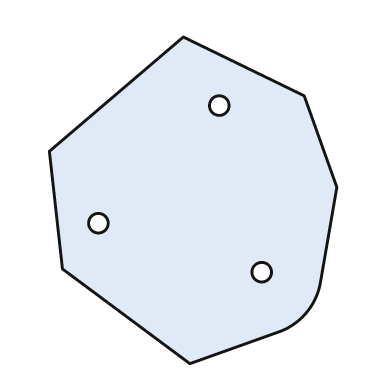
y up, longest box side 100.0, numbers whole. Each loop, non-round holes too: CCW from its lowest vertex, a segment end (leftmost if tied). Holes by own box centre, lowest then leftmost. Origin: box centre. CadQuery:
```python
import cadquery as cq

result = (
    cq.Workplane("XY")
    .moveTo(-1.0, -50.0)
    .lineTo(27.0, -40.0)
    .threePointArc((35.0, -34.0), (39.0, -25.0))
    .lineTo(44.0, 4.0)
    .lineTo(34.0, 32.0)
    .lineTo(-3.0, 50.0)
    .lineTo(-44.0, 15.0)
    .lineTo(-40.0, -21.0)
    .close()
    .moveTo(21.0, -22.0)
    .circle(3.0)
    .moveTo(-29.0, -7.0)
    .circle(3.0)
    .moveTo(8.0, 29.0)
    .circle(3.0)
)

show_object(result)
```